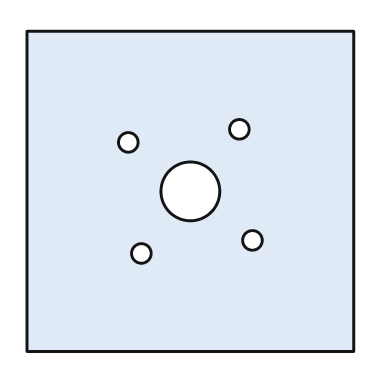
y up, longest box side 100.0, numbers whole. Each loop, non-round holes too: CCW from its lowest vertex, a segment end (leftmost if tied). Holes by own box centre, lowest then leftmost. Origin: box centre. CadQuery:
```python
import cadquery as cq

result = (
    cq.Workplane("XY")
    .moveTo(-50.0, -49.0)
    .lineTo(50.0, -49.0)
    .lineTo(50.0, 49.0)
    .lineTo(-50.0, 49.0)
    .close()
    .moveTo(-15.0, -19.0)
    .circle(3.0)
    .moveTo(19.0, -15.0)
    .circle(3.0)
    .moveTo(0.0, 0.0)
    .circle(9.0)
    .moveTo(-19.0, 15.0)
    .circle(3.0)
    .moveTo(15.0, 19.0)
    .circle(3.0)
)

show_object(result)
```